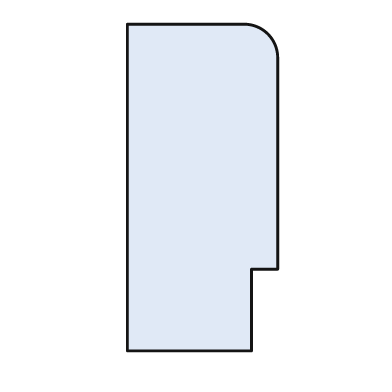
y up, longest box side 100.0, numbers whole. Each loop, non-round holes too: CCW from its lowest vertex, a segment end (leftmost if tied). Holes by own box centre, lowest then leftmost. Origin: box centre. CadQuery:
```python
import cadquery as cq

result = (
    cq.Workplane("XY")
    .moveTo(-23.0, -50.0)
    .lineTo(15.0, -50.0)
    .lineTo(15.0, -25.0)
    .lineTo(23.0, -25.0)
    .lineTo(23.0, 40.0)
    .threePointArc((20.0, 47.0), (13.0, 50.0))
    .lineTo(-23.0, 50.0)
    .close()
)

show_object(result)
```